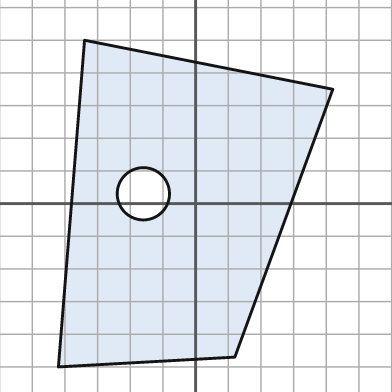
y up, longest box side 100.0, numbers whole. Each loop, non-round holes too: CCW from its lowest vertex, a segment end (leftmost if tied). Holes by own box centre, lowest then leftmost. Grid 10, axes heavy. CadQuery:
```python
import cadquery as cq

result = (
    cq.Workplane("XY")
    .moveTo(-42.0, -50.0)
    .lineTo(12.0, -47.0)
    .lineTo(42.0, 35.0)
    .lineTo(-34.0, 50.0)
    .close()
    .moveTo(-16.0, 3.0)
    .circle(8.0)
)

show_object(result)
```